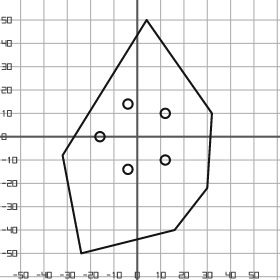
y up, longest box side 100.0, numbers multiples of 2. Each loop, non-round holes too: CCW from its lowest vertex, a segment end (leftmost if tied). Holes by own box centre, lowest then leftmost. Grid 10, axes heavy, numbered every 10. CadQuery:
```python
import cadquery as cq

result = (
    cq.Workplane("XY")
    .moveTo(-24.0, -50.0)
    .lineTo(16.0, -40.0)
    .lineTo(30.0, -22.0)
    .lineTo(32.0, 10.0)
    .lineTo(4.0, 50.0)
    .lineTo(-32.0, -8.0)
    .close()
    .moveTo(-4.0, -14.0)
    .circle(2.0)
    .moveTo(12.0, -10.0)
    .circle(2.0)
    .moveTo(-16.0, 0.0)
    .circle(2.0)
    .moveTo(12.0, 10.0)
    .circle(2.0)
    .moveTo(-4.0, 14.0)
    .circle(2.0)
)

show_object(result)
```